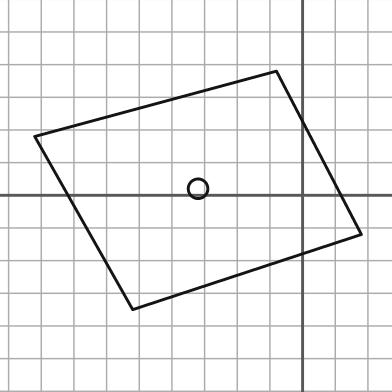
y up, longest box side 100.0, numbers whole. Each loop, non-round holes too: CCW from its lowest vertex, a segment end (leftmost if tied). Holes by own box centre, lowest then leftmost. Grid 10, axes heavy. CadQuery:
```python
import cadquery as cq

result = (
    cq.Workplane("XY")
    .moveTo(-52.0, -35.0)
    .lineTo(18.0, -12.0)
    .lineTo(-8.0, 38.0)
    .lineTo(-82.0, 18.0)
    .close()
    .moveTo(-32.0, 2.0)
    .circle(3.0)
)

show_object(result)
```